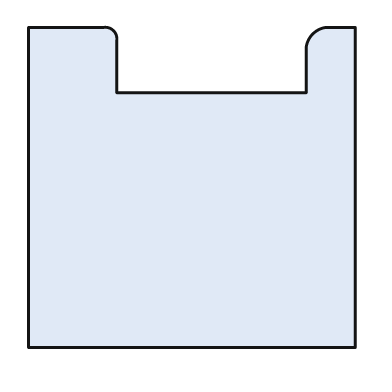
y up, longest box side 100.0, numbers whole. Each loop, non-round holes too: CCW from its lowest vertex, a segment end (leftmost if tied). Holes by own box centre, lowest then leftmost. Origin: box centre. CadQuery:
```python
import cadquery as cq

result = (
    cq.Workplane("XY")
    .moveTo(-50.0, -49.0)
    .lineTo(50.0, -49.0)
    .lineTo(50.0, 49.0)
    .lineTo(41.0, 49.0)
    .threePointArc((37.0, 47.0), (35.0, 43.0))
    .lineTo(35.0, 29.0)
    .lineTo(-23.0, 29.0)
    .lineTo(-23.0, 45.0)
    .threePointArc((-24.0, 48.0), (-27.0, 49.0))
    .lineTo(-50.0, 49.0)
    .close()
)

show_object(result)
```